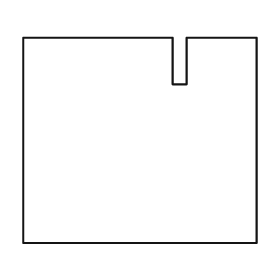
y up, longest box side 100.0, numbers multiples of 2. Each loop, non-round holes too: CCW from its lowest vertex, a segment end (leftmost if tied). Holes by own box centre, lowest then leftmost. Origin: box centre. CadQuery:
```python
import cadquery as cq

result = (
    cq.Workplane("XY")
    .moveTo(-50.0, -44.0)
    .lineTo(50.0, -44.0)
    .lineTo(50.0, 44.0)
    .lineTo(20.0, 44.0)
    .lineTo(20.0, 24.0)
    .lineTo(14.0, 24.0)
    .lineTo(14.0, 44.0)
    .lineTo(-50.0, 44.0)
    .close()
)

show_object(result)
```